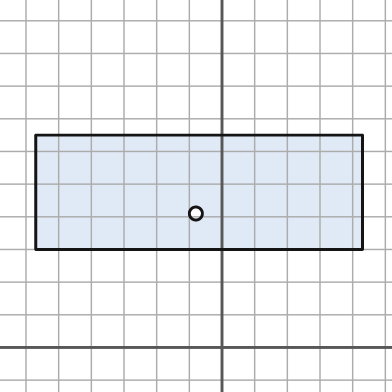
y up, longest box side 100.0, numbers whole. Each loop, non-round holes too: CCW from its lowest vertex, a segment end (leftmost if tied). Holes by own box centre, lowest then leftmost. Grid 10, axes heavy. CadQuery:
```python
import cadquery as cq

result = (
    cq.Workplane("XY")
    .moveTo(-57.0, 30.0)
    .lineTo(43.0, 30.0)
    .lineTo(43.0, 65.0)
    .lineTo(-57.0, 65.0)
    .close()
    .moveTo(-8.0, 41.0)
    .circle(2.0)
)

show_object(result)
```